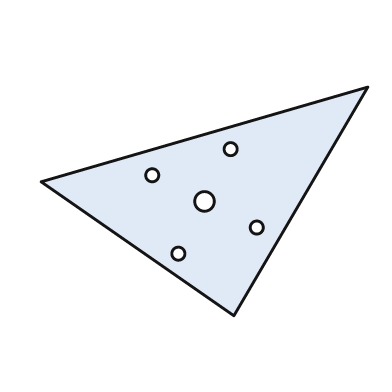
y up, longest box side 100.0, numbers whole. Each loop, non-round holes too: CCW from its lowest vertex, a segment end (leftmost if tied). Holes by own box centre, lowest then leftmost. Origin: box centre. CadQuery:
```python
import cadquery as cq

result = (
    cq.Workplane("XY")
    .moveTo(9.0, -35.0)
    .lineTo(50.0, 35.0)
    .lineTo(-50.0, 6.0)
    .close()
    .moveTo(-8.0, -16.0)
    .circle(2.0)
    .moveTo(16.0, -8.0)
    .circle(2.0)
    .moveTo(0.0, 0.0)
    .circle(3.0)
    .moveTo(-16.0, 8.0)
    .circle(2.0)
    .moveTo(8.0, 16.0)
    .circle(2.0)
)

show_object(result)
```